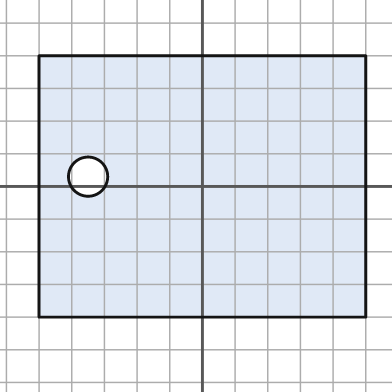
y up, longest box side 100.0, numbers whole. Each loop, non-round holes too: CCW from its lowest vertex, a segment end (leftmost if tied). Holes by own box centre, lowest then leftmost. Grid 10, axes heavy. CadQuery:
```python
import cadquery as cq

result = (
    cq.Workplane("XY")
    .moveTo(-50.0, -40.0)
    .lineTo(50.0, -40.0)
    .lineTo(50.0, 40.0)
    .lineTo(-50.0, 40.0)
    .close()
    .moveTo(-35.0, 3.0)
    .circle(6.0)
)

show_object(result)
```